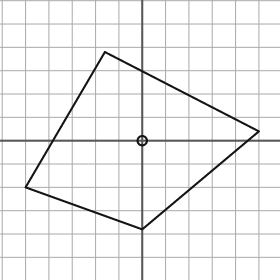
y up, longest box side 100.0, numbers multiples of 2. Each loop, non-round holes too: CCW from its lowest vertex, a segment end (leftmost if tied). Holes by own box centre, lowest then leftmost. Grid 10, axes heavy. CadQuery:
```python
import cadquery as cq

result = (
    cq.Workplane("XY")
    .moveTo(0.0, -38.0)
    .lineTo(50.0, 4.0)
    .lineTo(-16.0, 38.0)
    .lineTo(-50.0, -20.0)
    .close()
    .moveTo(0.0, 0.0)
    .circle(2.0)
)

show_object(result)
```